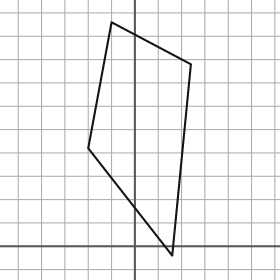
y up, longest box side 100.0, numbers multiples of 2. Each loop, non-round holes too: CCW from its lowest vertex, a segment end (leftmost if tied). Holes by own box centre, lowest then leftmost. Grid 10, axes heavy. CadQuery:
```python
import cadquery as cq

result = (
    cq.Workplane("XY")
    .moveTo(16.0, -4.0)
    .lineTo(24.0, 78.0)
    .lineTo(-10.0, 96.0)
    .lineTo(-20.0, 42.0)
    .close()
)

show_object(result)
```